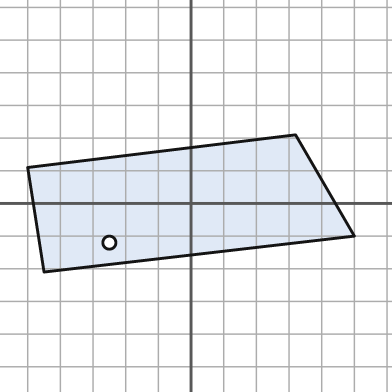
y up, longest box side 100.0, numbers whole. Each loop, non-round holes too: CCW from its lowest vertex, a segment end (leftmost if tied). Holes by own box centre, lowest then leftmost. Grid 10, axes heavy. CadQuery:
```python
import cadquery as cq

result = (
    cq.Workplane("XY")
    .moveTo(-45.0, -21.0)
    .lineTo(50.0, -10.0)
    .lineTo(32.0, 21.0)
    .lineTo(-50.0, 11.0)
    .close()
    .moveTo(-25.0, -12.0)
    .circle(2.0)
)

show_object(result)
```